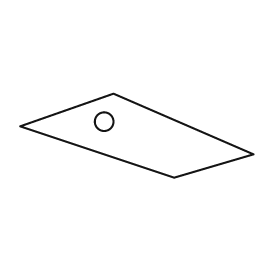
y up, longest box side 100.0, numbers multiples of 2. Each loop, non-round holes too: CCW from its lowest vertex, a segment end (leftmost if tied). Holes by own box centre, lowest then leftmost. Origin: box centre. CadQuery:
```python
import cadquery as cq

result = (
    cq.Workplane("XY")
    .moveTo(16.0, -18.0)
    .lineTo(50.0, -8.0)
    .lineTo(-10.0, 18.0)
    .lineTo(-50.0, 4.0)
    .close()
    .moveTo(-14.0, 6.0)
    .circle(4.0)
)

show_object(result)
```